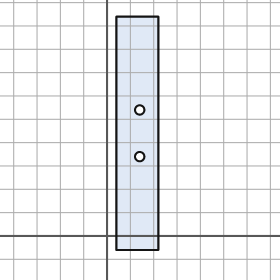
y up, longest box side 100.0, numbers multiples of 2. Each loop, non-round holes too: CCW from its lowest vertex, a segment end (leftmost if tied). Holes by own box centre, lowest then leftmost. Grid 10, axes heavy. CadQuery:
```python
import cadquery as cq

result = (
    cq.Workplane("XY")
    .moveTo(4.0, -6.0)
    .lineTo(22.0, -6.0)
    .lineTo(22.0, 94.0)
    .lineTo(4.0, 94.0)
    .close()
    .moveTo(14.0, 34.0)
    .circle(2.0)
    .moveTo(14.0, 54.0)
    .circle(2.0)
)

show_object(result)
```